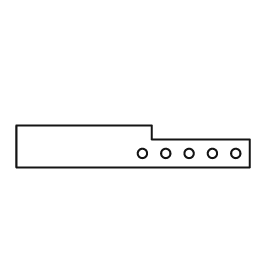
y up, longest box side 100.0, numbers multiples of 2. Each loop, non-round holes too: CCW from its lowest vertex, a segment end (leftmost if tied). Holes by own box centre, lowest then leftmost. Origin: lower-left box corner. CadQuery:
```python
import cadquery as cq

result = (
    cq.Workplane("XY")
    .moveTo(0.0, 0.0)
    .lineTo(100.0, 0.0)
    .lineTo(100.0, 12.0)
    .lineTo(58.0, 12.0)
    .lineTo(58.0, 18.0)
    .lineTo(0.0, 18.0)
    .close()
    .moveTo(54.0, 6.0)
    .circle(2.0)
    .moveTo(64.0, 6.0)
    .circle(2.0)
    .moveTo(74.0, 6.0)
    .circle(2.0)
    .moveTo(84.0, 6.0)
    .circle(2.0)
    .moveTo(94.0, 6.0)
    .circle(2.0)
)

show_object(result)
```